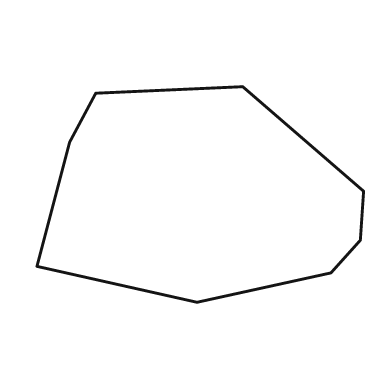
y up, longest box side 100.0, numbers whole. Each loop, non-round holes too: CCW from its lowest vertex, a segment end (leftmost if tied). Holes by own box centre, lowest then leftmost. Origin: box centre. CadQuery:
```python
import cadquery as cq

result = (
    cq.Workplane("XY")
    .moveTo(-1.0, -33.0)
    .lineTo(40.0, -24.0)
    .lineTo(49.0, -14.0)
    .lineTo(50.0, 1.0)
    .lineTo(13.0, 33.0)
    .lineTo(-32.0, 31.0)
    .lineTo(-40.0, 16.0)
    .lineTo(-50.0, -22.0)
    .close()
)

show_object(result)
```